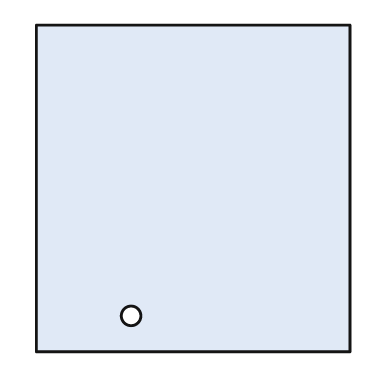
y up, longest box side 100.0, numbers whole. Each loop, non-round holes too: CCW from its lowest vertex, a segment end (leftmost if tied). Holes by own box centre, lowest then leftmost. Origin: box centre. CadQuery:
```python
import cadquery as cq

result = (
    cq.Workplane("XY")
    .moveTo(-48.0, -50.0)
    .lineTo(48.0, -50.0)
    .lineTo(48.0, 50.0)
    .lineTo(-48.0, 50.0)
    .close()
    .moveTo(-19.0, -39.0)
    .circle(3.0)
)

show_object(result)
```